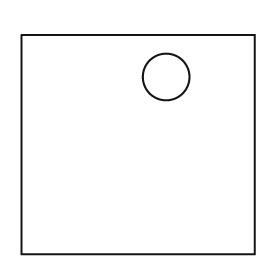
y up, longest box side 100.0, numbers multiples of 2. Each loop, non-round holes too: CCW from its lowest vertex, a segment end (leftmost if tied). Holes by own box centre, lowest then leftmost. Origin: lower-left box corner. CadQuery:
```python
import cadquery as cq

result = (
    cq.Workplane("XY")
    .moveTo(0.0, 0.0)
    .lineTo(100.0, 0.0)
    .lineTo(100.0, 94.0)
    .lineTo(0.0, 94.0)
    .close()
    .moveTo(62.0, 76.0)
    .circle(10.0)
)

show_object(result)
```